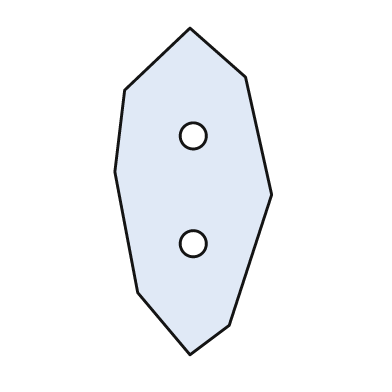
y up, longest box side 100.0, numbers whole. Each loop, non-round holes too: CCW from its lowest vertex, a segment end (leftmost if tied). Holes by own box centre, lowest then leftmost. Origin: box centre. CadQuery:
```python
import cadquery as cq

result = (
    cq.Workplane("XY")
    .moveTo(-1.0, -50.0)
    .lineTo(11.0, -41.0)
    .lineTo(24.0, -1.0)
    .lineTo(16.0, 35.0)
    .lineTo(-1.0, 50.0)
    .lineTo(-21.0, 31.0)
    .lineTo(-24.0, 6.0)
    .lineTo(-17.0, -31.0)
    .close()
    .moveTo(0.0, -16.0)
    .circle(4.0)
    .moveTo(0.0, 17.0)
    .circle(4.0)
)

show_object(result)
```